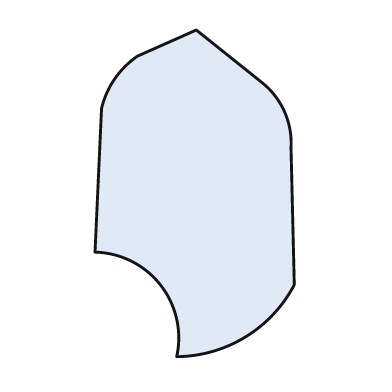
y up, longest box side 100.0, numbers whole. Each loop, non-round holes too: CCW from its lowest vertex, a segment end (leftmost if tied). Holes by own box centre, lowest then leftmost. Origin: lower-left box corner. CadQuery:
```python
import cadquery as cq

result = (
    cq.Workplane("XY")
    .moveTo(25.0, 0.0)
    .threePointArc((46.0, 6.0), (61.0, 22.0))
    .lineTo(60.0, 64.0)
    .threePointArc((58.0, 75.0), (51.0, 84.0))
    .lineTo(31.0, 100.0)
    .lineTo(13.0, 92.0)
    .threePointArc((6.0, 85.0), (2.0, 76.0))
    .lineTo(0.0, 32.0)
    .threePointArc((20.0, 22.0), (25.0, 0.0))
    .close()
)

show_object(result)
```